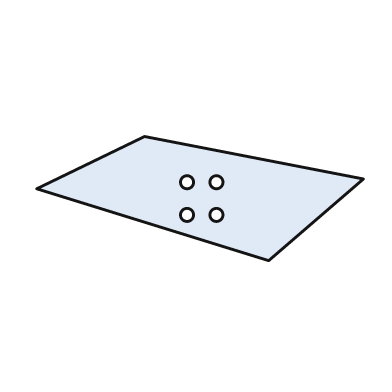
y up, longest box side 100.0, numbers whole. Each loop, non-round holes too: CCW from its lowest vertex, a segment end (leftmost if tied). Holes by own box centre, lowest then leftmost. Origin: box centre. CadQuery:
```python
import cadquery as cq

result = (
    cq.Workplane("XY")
    .moveTo(21.0, -19.0)
    .lineTo(50.0, 6.0)
    .lineTo(-17.0, 19.0)
    .lineTo(-50.0, 3.0)
    .close()
    .moveTo(-4.0, -5.0)
    .circle(2.0)
    .moveTo(5.0, -5.0)
    .circle(2.0)
    .moveTo(-4.0, 5.0)
    .circle(2.0)
    .moveTo(5.0, 5.0)
    .circle(2.0)
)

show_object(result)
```